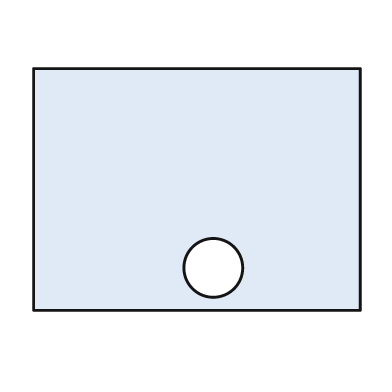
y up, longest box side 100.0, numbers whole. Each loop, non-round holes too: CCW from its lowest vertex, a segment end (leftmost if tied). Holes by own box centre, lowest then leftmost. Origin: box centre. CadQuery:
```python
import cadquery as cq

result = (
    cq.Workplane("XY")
    .moveTo(-50.0, -37.0)
    .lineTo(50.0, -37.0)
    .lineTo(50.0, 37.0)
    .lineTo(-50.0, 37.0)
    .close()
    .moveTo(5.0, -24.0)
    .circle(9.0)
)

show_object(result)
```